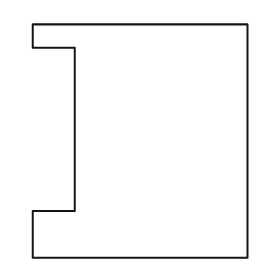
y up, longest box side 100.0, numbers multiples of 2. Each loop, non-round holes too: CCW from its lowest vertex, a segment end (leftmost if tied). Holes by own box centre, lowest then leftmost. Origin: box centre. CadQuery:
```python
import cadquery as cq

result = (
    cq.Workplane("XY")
    .moveTo(-46.0, -50.0)
    .lineTo(46.0, -50.0)
    .lineTo(46.0, 50.0)
    .lineTo(-46.0, 50.0)
    .lineTo(-46.0, 40.0)
    .lineTo(-28.0, 40.0)
    .lineTo(-28.0, -30.0)
    .lineTo(-46.0, -30.0)
    .close()
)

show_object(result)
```